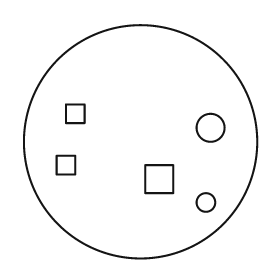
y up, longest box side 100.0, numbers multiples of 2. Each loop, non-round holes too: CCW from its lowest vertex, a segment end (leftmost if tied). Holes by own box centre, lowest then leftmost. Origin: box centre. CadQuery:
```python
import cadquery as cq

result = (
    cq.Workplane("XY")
    .moveTo(0.0, 0.0)
    .circle(50.0)
    .moveTo(28.0, -26.0)
    .circle(4.0)
    .moveTo(2.0, -22.0)
    .lineTo(14.0, -22.0)
    .lineTo(14.0, -10.0)
    .lineTo(2.0, -10.0)
    .close()
    .moveTo(-36.0, -14.0)
    .lineTo(-28.0, -14.0)
    .lineTo(-28.0, -6.0)
    .lineTo(-36.0, -6.0)
    .close()
    .moveTo(30.0, 6.0)
    .circle(6.0)
    .moveTo(-32.0, 8.0)
    .lineTo(-24.0, 8.0)
    .lineTo(-24.0, 16.0)
    .lineTo(-32.0, 16.0)
    .close()
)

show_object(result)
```